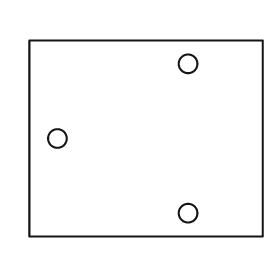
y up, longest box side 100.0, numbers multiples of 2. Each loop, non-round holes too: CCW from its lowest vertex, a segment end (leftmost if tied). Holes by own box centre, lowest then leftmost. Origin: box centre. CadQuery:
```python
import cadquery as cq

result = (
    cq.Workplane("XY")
    .moveTo(-50.0, -42.0)
    .lineTo(50.0, -42.0)
    .lineTo(50.0, 42.0)
    .lineTo(-50.0, 42.0)
    .close()
    .moveTo(18.0, -32.0)
    .circle(4.0)
    .moveTo(-38.0, 0.0)
    .circle(4.0)
    .moveTo(18.0, 32.0)
    .circle(4.0)
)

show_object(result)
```